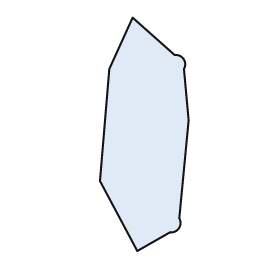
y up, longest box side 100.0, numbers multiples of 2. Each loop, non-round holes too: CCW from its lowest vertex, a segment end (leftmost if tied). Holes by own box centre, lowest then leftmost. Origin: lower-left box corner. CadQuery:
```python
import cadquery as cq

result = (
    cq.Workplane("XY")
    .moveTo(16.0, 0.0)
    .lineTo(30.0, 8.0)
    .threePointArc((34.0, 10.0), (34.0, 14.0))
    .lineTo(38.0, 56.0)
    .lineTo(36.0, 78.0)
    .threePointArc((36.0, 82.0), (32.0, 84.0))
    .lineTo(14.0, 100.0)
    .lineTo(4.0, 78.0)
    .lineTo(0.0, 30.0)
    .close()
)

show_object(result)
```